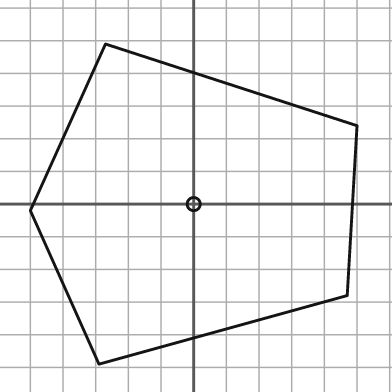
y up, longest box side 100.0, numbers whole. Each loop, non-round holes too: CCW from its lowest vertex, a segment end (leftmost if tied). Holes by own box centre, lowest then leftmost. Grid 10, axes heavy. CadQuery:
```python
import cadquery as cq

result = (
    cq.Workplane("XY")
    .moveTo(-29.0, -49.0)
    .lineTo(47.0, -28.0)
    .lineTo(50.0, 24.0)
    .lineTo(-27.0, 49.0)
    .lineTo(-50.0, -2.0)
    .close()
    .moveTo(0.0, 0.0)
    .circle(2.0)
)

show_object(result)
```